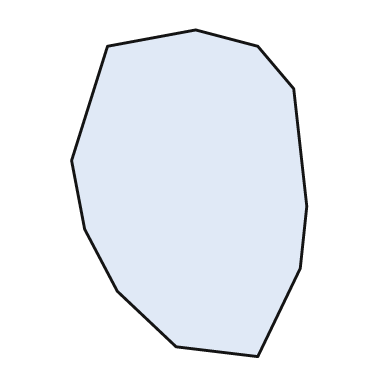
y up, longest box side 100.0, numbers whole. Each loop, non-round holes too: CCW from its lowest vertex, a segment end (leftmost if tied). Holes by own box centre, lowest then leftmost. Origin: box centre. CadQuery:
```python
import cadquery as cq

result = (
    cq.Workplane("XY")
    .moveTo(21.0, -50.0)
    .lineTo(34.0, -23.0)
    .lineTo(36.0, -4.0)
    .lineTo(32.0, 32.0)
    .lineTo(21.0, 45.0)
    .lineTo(2.0, 50.0)
    .lineTo(-25.0, 45.0)
    .lineTo(-36.0, 10.0)
    .lineTo(-32.0, -11.0)
    .lineTo(-22.0, -30.0)
    .lineTo(-4.0, -47.0)
    .close()
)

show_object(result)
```